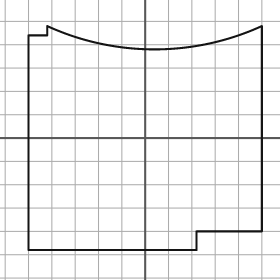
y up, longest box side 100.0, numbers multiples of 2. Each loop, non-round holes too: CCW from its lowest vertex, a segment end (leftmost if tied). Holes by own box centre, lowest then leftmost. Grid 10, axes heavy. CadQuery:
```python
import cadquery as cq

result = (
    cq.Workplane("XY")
    .moveTo(-50.0, -48.0)
    .lineTo(22.0, -48.0)
    .lineTo(22.0, -40.0)
    .lineTo(50.0, -40.0)
    .lineTo(50.0, 48.0)
    .threePointArc((4.0, 38.0), (-42.0, 48.0))
    .lineTo(-42.0, 44.0)
    .lineTo(-50.0, 44.0)
    .close()
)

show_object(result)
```